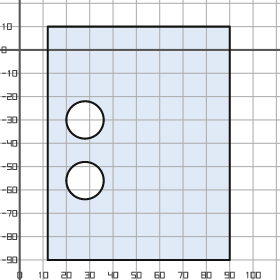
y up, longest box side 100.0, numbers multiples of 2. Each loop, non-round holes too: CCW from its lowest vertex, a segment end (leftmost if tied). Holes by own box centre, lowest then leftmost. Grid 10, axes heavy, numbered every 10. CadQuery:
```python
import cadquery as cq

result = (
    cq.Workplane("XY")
    .moveTo(12.0, -90.0)
    .lineTo(90.0, -90.0)
    .lineTo(90.0, 10.0)
    .lineTo(12.0, 10.0)
    .close()
    .moveTo(28.0, -56.0)
    .circle(8.0)
    .moveTo(28.0, -30.0)
    .circle(8.0)
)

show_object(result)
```